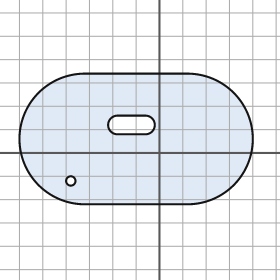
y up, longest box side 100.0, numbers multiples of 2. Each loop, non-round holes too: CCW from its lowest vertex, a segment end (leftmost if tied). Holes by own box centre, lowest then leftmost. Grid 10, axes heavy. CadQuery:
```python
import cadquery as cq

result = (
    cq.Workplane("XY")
    .moveTo(-32.0, -22.0)
    .lineTo(12.0, -22.0)
    .threePointArc((40.0, 6.0), (12.0, 34.0))
    .lineTo(-32.0, 34.0)
    .threePointArc((-60.0, 6.0), (-32.0, -22.0))
    .close()
    .moveTo(-38.0, -12.0)
    .circle(2.0)
    .moveTo(-18.0, 8.0)
    .lineTo(-6.0, 8.0)
    .threePointArc((-2.0, 12.0), (-6.0, 16.0))
    .lineTo(-18.0, 16.0)
    .threePointArc((-22.0, 12.0), (-18.0, 8.0))
    .close()
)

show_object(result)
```